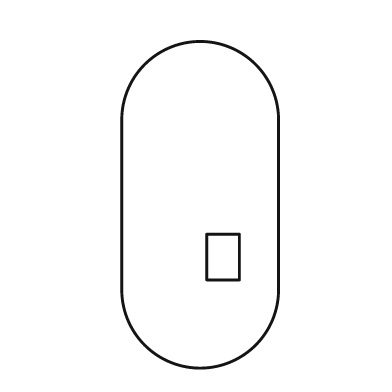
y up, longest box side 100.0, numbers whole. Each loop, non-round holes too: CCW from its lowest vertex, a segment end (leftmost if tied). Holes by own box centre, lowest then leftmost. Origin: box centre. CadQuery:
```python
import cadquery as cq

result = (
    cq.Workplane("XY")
    .moveTo(-24.0, -26.0)
    .threePointArc((0.0, -50.0), (24.0, -26.0))
    .lineTo(24.0, 26.0)
    .threePointArc((0.0, 50.0), (-24.0, 26.0))
    .close()
    .moveTo(2.0, -23.0)
    .lineTo(12.0, -23.0)
    .lineTo(12.0, -9.0)
    .lineTo(2.0, -9.0)
    .close()
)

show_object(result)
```